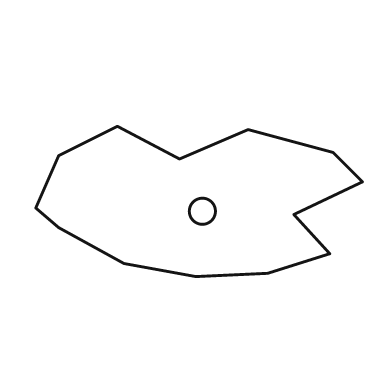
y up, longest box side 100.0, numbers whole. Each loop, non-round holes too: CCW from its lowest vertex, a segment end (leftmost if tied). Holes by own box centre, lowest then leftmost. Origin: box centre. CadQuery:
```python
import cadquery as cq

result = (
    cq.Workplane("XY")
    .moveTo(-1.0, -23.0)
    .lineTo(21.0, -22.0)
    .lineTo(40.0, -16.0)
    .lineTo(29.0, -4.0)
    .lineTo(50.0, 6.0)
    .lineTo(41.0, 15.0)
    .lineTo(15.0, 22.0)
    .lineTo(-6.0, 13.0)
    .lineTo(-25.0, 23.0)
    .lineTo(-43.0, 14.0)
    .lineTo(-50.0, -2.0)
    .lineTo(-43.0, -8.0)
    .lineTo(-23.0, -19.0)
    .close()
    .moveTo(1.0, -3.0)
    .circle(4.0)
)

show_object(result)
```